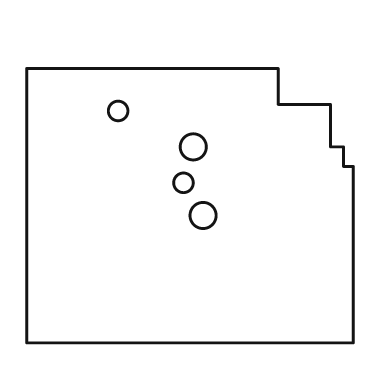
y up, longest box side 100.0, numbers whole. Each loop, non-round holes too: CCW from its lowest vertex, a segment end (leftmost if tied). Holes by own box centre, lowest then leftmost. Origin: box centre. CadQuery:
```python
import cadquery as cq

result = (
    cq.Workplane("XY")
    .moveTo(-50.0, -42.0)
    .lineTo(50.0, -42.0)
    .lineTo(50.0, 12.0)
    .lineTo(47.0, 12.0)
    .lineTo(47.0, 18.0)
    .lineTo(43.0, 18.0)
    .lineTo(43.0, 31.0)
    .lineTo(27.0, 31.0)
    .lineTo(27.0, 42.0)
    .lineTo(-50.0, 42.0)
    .close()
    .moveTo(4.0, -3.0)
    .circle(4.0)
    .moveTo(-2.0, 7.0)
    .circle(3.0)
    .moveTo(1.0, 18.0)
    .circle(4.0)
    .moveTo(-22.0, 29.0)
    .circle(3.0)
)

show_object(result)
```